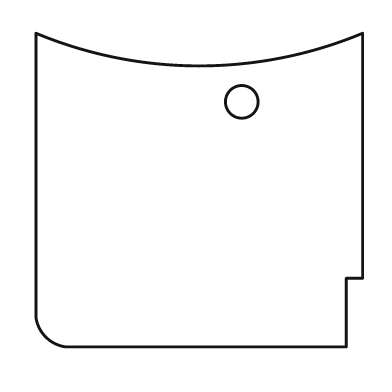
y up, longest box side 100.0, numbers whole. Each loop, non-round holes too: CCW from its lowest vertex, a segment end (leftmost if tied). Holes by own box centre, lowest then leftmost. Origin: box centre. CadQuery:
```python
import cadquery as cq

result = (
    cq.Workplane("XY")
    .moveTo(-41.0, -48.0)
    .lineTo(45.0, -48.0)
    .lineTo(45.0, -27.0)
    .lineTo(50.0, -27.0)
    .lineTo(50.0, 48.0)
    .threePointArc((0.0, 38.0), (-50.0, 48.0))
    .lineTo(-50.0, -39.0)
    .threePointArc((-47.0, -45.0), (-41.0, -48.0))
    .close()
    .moveTo(13.0, 27.0)
    .circle(5.0)
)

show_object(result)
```